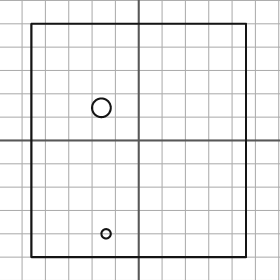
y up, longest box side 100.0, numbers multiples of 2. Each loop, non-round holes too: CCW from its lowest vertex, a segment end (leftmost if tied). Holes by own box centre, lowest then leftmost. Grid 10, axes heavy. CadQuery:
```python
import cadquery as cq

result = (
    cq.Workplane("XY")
    .moveTo(-46.0, -50.0)
    .lineTo(46.0, -50.0)
    .lineTo(46.0, 50.0)
    .lineTo(-46.0, 50.0)
    .close()
    .moveTo(-14.0, -40.0)
    .circle(2.0)
    .moveTo(-16.0, 14.0)
    .circle(4.0)
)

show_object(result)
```